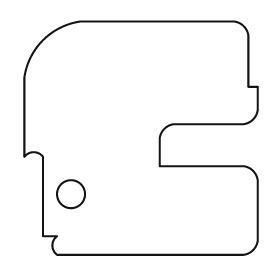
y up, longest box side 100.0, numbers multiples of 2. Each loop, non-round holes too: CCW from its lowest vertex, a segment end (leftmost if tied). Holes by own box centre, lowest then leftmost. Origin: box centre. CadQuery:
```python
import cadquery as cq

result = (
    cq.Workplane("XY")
    .moveTo(-36.0, -50.0)
    .lineTo(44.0, -50.0)
    .threePointArc((48.0, -48.0), (50.0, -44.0))
    .lineTo(50.0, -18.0)
    .threePointArc((48.0, -14.0), (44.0, -12.0))
    .lineTo(8.0, -12.0)
    .lineTo(8.0, 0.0)
    .threePointArc((10.0, 4.0), (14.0, 6.0))
    .lineTo(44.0, 6.0)
    .threePointArc((48.0, 8.0), (50.0, 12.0))
    .lineTo(50.0, 22.0)
    .lineTo(46.0, 22.0)
    .lineTo(46.0, 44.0)
    .threePointArc((44.0, 48.0), (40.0, 50.0))
    .lineTo(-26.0, 50.0)
    .threePointArc((-42.0, 42.0), (-50.0, 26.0))
    .lineTo(-50.0, -8.0)
    .threePointArc((-46.0, -6.0), (-42.0, -8.0))
    .lineTo(-42.0, -42.0)
    .lineTo(-36.0, -42.0)
    .threePointArc((-38.0, -46.0), (-36.0, -50.0))
    .close()
    .moveTo(-30.0, -24.0)
    .circle(6.0)
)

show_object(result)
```